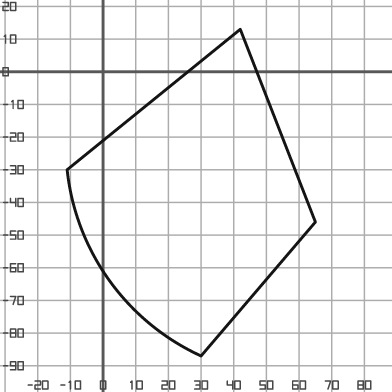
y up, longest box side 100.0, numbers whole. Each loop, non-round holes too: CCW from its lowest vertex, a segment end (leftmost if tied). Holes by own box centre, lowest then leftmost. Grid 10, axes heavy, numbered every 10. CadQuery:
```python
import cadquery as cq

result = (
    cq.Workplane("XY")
    .moveTo(30.0, -87.0)
    .lineTo(65.0, -46.0)
    .lineTo(42.0, 13.0)
    .lineTo(-11.0, -30.0)
    .threePointArc((2.0, -64.0), (30.0, -87.0))
    .close()
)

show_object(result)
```